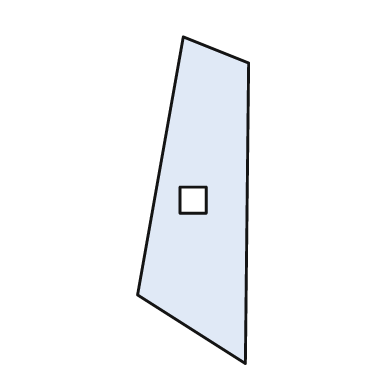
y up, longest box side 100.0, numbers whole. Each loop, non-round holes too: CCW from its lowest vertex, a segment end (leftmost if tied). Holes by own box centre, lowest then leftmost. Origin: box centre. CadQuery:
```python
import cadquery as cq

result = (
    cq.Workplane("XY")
    .moveTo(16.0, -50.0)
    .lineTo(17.0, 42.0)
    .lineTo(-3.0, 50.0)
    .lineTo(-17.0, -29.0)
    .close()
    .moveTo(-4.0, -4.0)
    .lineTo(4.0, -4.0)
    .lineTo(4.0, 4.0)
    .lineTo(-4.0, 4.0)
    .close()
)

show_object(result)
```